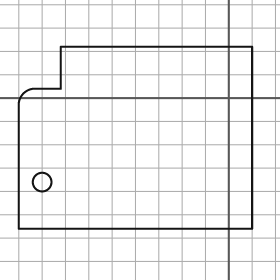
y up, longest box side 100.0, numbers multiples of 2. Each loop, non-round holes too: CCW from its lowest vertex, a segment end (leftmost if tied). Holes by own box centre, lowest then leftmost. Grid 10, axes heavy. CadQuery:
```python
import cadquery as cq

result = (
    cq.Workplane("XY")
    .moveTo(-90.0, -56.0)
    .lineTo(10.0, -56.0)
    .lineTo(10.0, 22.0)
    .lineTo(-72.0, 22.0)
    .lineTo(-72.0, 4.0)
    .lineTo(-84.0, 4.0)
    .threePointArc((-88.0, 2.0), (-90.0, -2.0))
    .close()
    .moveTo(-80.0, -36.0)
    .circle(4.0)
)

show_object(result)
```